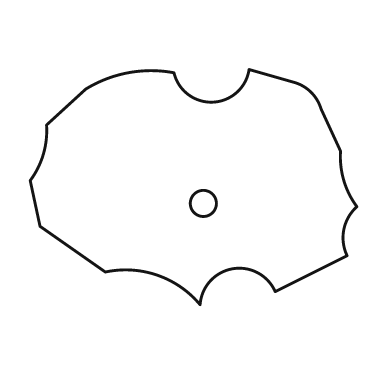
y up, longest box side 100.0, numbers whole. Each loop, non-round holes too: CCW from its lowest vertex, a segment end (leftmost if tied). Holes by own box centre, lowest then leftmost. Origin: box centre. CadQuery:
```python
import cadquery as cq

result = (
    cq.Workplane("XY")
    .moveTo(2.0, -36.0)
    .threePointArc((12.0, -25.0), (25.0, -32.0))
    .lineTo(47.0, -21.0)
    .threePointArc((46.0, -13.0), (50.0, -6.0))
    .threePointArc((46.0, 2.0), (45.0, 11.0))
    .lineTo(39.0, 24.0)
    .threePointArc((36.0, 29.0), (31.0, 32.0))
    .lineTo(17.0, 36.0)
    .threePointArc((6.0, 26.0), (-6.0, 35.0))
    .threePointArc((-20.0, 35.0), (-33.0, 30.0))
    .lineTo(-45.0, 19.0)
    .threePointArc((-46.0, 10.0), (-50.0, 2.0))
    .lineTo(-47.0, -12.0)
    .lineTo(-27.0, -26.0)
    .threePointArc((-11.0, -27.0), (2.0, -36.0))
    .close()
    .moveTo(3.0, -5.0)
    .circle(4.0)
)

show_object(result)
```